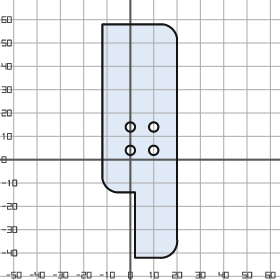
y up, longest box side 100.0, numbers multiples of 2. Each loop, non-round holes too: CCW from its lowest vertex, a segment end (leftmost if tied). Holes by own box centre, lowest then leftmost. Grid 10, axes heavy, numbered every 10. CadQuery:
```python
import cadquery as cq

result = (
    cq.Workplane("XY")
    .moveTo(2.0, -42.0)
    .lineTo(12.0, -42.0)
    .threePointArc((18.0, -40.0), (20.0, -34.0))
    .lineTo(20.0, 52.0)
    .threePointArc((18.0, 56.0), (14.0, 58.0))
    .lineTo(-12.0, 58.0)
    .lineTo(-12.0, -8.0)
    .threePointArc((-10.0, -12.0), (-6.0, -14.0))
    .lineTo(2.0, -14.0)
    .close()
    .moveTo(0.0, 4.0)
    .circle(2.0)
    .moveTo(10.0, 4.0)
    .circle(2.0)
    .moveTo(0.0, 14.0)
    .circle(2.0)
    .moveTo(10.0, 14.0)
    .circle(2.0)
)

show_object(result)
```